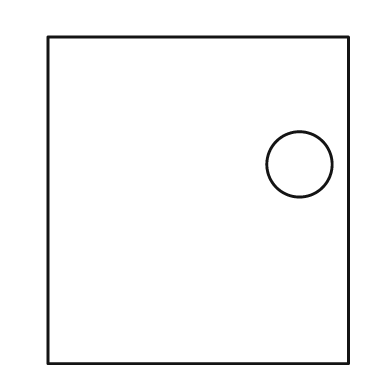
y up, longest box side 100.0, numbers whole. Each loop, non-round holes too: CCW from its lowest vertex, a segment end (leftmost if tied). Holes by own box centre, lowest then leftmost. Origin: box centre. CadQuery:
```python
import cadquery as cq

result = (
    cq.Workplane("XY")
    .moveTo(-46.0, -50.0)
    .lineTo(46.0, -50.0)
    .lineTo(46.0, 50.0)
    .lineTo(-46.0, 50.0)
    .close()
    .moveTo(31.0, 11.0)
    .circle(10.0)
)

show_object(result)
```